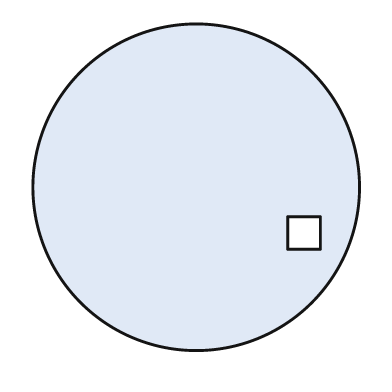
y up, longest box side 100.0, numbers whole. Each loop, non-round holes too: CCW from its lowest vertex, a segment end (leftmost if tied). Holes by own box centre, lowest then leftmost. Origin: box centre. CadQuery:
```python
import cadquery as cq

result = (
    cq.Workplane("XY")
    .moveTo(0.0, 0.0)
    .circle(50.0)
    .moveTo(28.0, -19.0)
    .lineTo(38.0, -19.0)
    .lineTo(38.0, -9.0)
    .lineTo(28.0, -9.0)
    .close()
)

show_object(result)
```